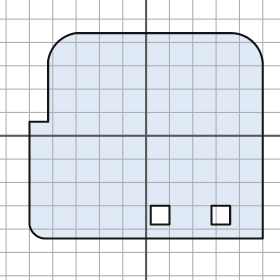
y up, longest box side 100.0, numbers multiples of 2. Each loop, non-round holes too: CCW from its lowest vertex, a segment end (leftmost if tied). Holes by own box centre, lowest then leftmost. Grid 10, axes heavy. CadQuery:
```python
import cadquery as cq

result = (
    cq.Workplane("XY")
    .moveTo(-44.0, -44.0)
    .lineTo(50.0, -44.0)
    .lineTo(50.0, 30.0)
    .threePointArc((46.0, 40.0), (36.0, 44.0))
    .lineTo(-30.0, 44.0)
    .threePointArc((-38.0, 40.0), (-42.0, 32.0))
    .lineTo(-42.0, 6.0)
    .lineTo(-50.0, 6.0)
    .lineTo(-50.0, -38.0)
    .threePointArc((-48.0, -42.0), (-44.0, -44.0))
    .close()
    .moveTo(2.0, -38.0)
    .lineTo(10.0, -38.0)
    .lineTo(10.0, -30.0)
    .lineTo(2.0, -30.0)
    .close()
    .moveTo(28.0, -38.0)
    .lineTo(36.0, -38.0)
    .lineTo(36.0, -30.0)
    .lineTo(28.0, -30.0)
    .close()
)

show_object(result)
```